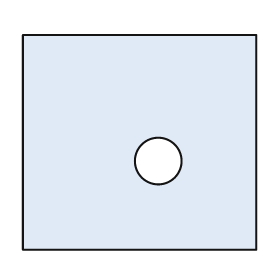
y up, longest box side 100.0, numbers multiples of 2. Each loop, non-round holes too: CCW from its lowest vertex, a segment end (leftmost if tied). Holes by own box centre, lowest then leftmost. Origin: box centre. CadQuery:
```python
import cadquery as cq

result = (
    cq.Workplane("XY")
    .moveTo(-50.0, -46.0)
    .lineTo(50.0, -46.0)
    .lineTo(50.0, 46.0)
    .lineTo(-50.0, 46.0)
    .close()
    .moveTo(8.0, -8.0)
    .circle(10.0)
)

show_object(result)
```